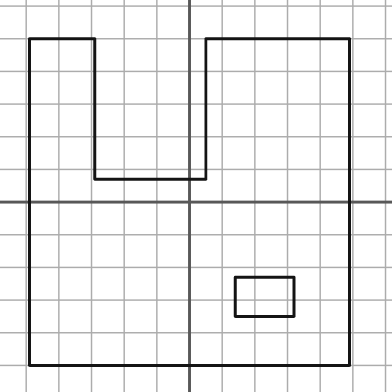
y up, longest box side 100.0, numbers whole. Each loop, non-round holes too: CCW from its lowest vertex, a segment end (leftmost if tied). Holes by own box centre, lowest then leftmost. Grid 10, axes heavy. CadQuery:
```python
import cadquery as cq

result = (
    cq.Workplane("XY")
    .moveTo(-49.0, -50.0)
    .lineTo(49.0, -50.0)
    .lineTo(49.0, 50.0)
    .lineTo(5.0, 50.0)
    .lineTo(5.0, 7.0)
    .lineTo(-29.0, 7.0)
    .lineTo(-29.0, 50.0)
    .lineTo(-49.0, 50.0)
    .close()
    .moveTo(14.0, -35.0)
    .lineTo(32.0, -35.0)
    .lineTo(32.0, -23.0)
    .lineTo(14.0, -23.0)
    .close()
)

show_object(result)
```